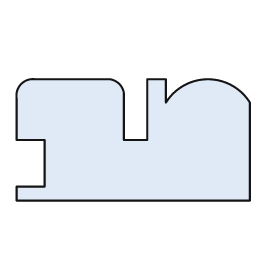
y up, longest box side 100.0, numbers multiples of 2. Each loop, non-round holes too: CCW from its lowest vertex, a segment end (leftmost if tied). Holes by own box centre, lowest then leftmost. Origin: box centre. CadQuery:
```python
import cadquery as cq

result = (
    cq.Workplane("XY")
    .moveTo(-50.0, -26.0)
    .lineTo(50.0, -26.0)
    .lineTo(50.0, 16.0)
    .threePointArc((32.0, 26.0), (14.0, 16.0))
    .lineTo(14.0, 26.0)
    .lineTo(6.0, 26.0)
    .lineTo(6.0, 0.0)
    .lineTo(-4.0, 0.0)
    .lineTo(-4.0, 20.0)
    .threePointArc((-6.0, 24.0), (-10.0, 26.0))
    .lineTo(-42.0, 26.0)
    .threePointArc((-48.0, 24.0), (-50.0, 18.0))
    .lineTo(-50.0, 0.0)
    .lineTo(-38.0, 0.0)
    .lineTo(-38.0, -20.0)
    .lineTo(-50.0, -20.0)
    .close()
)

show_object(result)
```